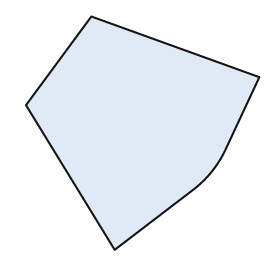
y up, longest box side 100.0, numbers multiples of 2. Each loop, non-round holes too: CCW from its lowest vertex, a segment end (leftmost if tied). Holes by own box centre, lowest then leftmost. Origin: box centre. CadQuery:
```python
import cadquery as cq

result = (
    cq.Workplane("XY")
    .moveTo(-12.0, -50.0)
    .lineTo(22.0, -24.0)
    .threePointArc((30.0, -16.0), (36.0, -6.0))
    .lineTo(50.0, 24.0)
    .lineTo(-22.0, 50.0)
    .lineTo(-50.0, 12.0)
    .close()
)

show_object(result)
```